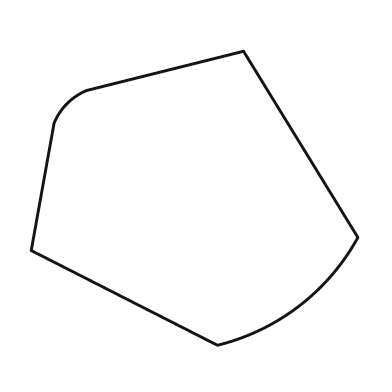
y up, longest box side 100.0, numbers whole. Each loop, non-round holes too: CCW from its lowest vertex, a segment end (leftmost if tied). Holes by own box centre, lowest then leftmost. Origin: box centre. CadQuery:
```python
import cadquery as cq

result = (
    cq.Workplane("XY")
    .moveTo(7.0, -45.0)
    .threePointArc((32.0, -33.0), (50.0, -12.0))
    .lineTo(15.0, 45.0)
    .lineTo(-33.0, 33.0)
    .threePointArc((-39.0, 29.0), (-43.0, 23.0))
    .lineTo(-50.0, -16.0)
    .close()
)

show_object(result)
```